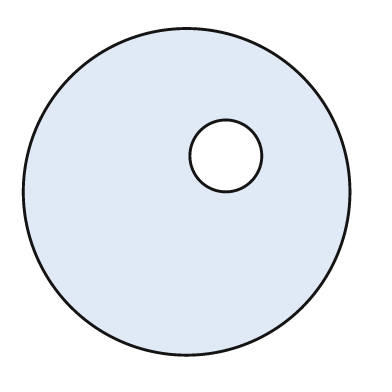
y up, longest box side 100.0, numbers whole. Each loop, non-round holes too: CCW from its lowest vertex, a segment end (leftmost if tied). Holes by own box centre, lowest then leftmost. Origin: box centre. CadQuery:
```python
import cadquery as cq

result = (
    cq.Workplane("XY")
    .moveTo(0.0, 0.0)
    .circle(50.0)
    .moveTo(12.0, 11.0)
    .circle(11.0)
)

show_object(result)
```